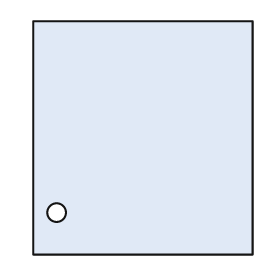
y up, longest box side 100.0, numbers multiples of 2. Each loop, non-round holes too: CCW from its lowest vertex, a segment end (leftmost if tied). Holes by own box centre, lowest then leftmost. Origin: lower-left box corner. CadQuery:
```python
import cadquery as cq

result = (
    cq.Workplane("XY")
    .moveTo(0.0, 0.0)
    .lineTo(94.0, 0.0)
    .lineTo(94.0, 100.0)
    .lineTo(0.0, 100.0)
    .close()
    .moveTo(10.0, 18.0)
    .circle(4.0)
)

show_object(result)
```